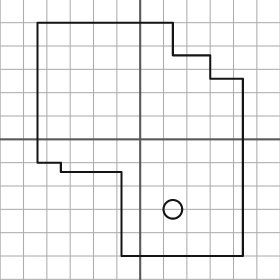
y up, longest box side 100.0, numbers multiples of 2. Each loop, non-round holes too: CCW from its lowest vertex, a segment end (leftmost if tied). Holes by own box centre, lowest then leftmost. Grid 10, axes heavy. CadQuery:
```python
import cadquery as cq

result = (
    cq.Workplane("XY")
    .moveTo(-8.0, -50.0)
    .lineTo(44.0, -50.0)
    .lineTo(44.0, 26.0)
    .lineTo(30.0, 26.0)
    .lineTo(30.0, 36.0)
    .lineTo(14.0, 36.0)
    .lineTo(14.0, 50.0)
    .lineTo(-44.0, 50.0)
    .lineTo(-44.0, -10.0)
    .lineTo(-34.0, -10.0)
    .lineTo(-34.0, -14.0)
    .lineTo(-8.0, -14.0)
    .close()
    .moveTo(14.0, -30.0)
    .circle(4.0)
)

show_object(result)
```